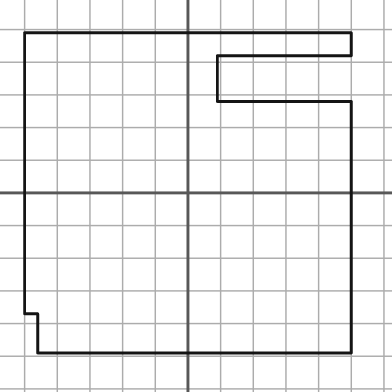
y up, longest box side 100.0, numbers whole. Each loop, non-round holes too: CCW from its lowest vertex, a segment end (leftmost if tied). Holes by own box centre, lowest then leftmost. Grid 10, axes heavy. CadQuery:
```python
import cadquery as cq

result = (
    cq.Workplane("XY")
    .moveTo(-46.0, -49.0)
    .lineTo(50.0, -49.0)
    .lineTo(50.0, 28.0)
    .lineTo(9.0, 28.0)
    .lineTo(9.0, 42.0)
    .lineTo(50.0, 42.0)
    .lineTo(50.0, 49.0)
    .lineTo(-50.0, 49.0)
    .lineTo(-50.0, -37.0)
    .lineTo(-46.0, -37.0)
    .close()
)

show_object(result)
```